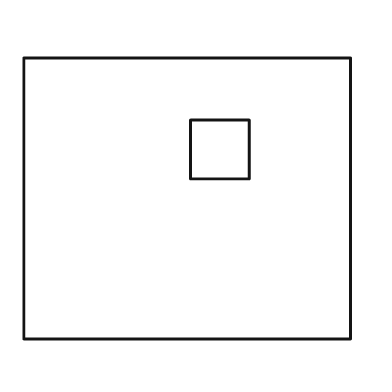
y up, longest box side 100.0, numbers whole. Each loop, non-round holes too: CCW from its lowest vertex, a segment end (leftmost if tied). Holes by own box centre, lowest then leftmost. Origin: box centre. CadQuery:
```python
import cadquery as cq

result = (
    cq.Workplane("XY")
    .moveTo(-50.0, -43.0)
    .lineTo(50.0, -43.0)
    .lineTo(50.0, 43.0)
    .lineTo(-50.0, 43.0)
    .close()
    .moveTo(1.0, 6.0)
    .lineTo(19.0, 6.0)
    .lineTo(19.0, 24.0)
    .lineTo(1.0, 24.0)
    .close()
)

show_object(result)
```